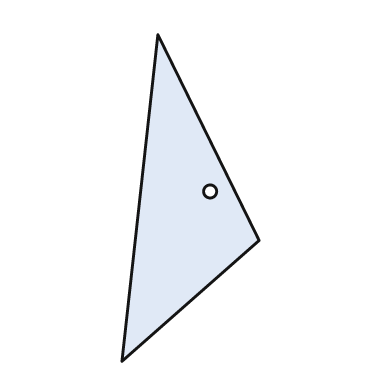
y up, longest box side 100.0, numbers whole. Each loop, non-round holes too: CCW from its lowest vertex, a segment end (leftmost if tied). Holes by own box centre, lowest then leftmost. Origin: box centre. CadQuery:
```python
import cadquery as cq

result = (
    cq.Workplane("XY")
    .moveTo(-21.0, -50.0)
    .lineTo(21.0, -13.0)
    .lineTo(-10.0, 50.0)
    .close()
    .moveTo(6.0, 2.0)
    .circle(2.0)
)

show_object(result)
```